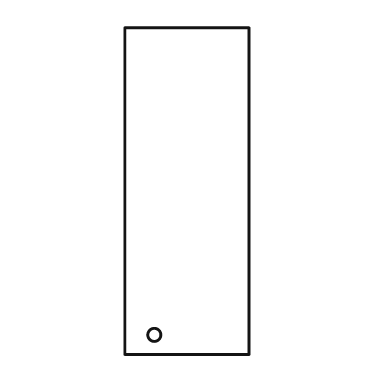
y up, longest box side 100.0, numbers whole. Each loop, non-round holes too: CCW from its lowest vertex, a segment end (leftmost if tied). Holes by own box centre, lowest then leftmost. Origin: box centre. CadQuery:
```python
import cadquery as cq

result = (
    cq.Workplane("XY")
    .moveTo(-19.0, -50.0)
    .lineTo(19.0, -50.0)
    .lineTo(19.0, 50.0)
    .lineTo(-19.0, 50.0)
    .close()
    .moveTo(-10.0, -44.0)
    .circle(2.0)
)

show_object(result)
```